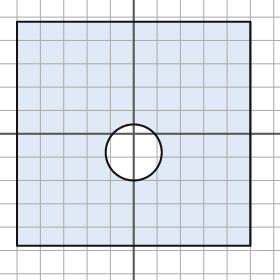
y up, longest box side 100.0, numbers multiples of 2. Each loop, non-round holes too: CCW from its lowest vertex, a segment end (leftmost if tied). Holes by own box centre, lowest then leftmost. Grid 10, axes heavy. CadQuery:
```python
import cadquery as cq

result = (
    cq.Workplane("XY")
    .moveTo(-50.0, -48.0)
    .lineTo(50.0, -48.0)
    .lineTo(50.0, 48.0)
    .lineTo(-50.0, 48.0)
    .close()
    .moveTo(0.0, -8.0)
    .circle(12.0)
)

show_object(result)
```